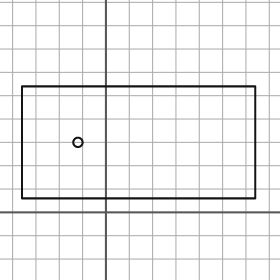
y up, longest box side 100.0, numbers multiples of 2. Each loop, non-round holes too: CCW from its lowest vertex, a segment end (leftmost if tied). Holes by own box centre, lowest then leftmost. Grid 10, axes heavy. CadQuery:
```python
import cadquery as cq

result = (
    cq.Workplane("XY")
    .moveTo(-36.0, 6.0)
    .lineTo(64.0, 6.0)
    .lineTo(64.0, 54.0)
    .lineTo(-36.0, 54.0)
    .close()
    .moveTo(-12.0, 30.0)
    .circle(2.0)
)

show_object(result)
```